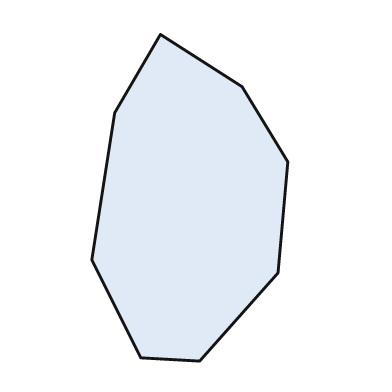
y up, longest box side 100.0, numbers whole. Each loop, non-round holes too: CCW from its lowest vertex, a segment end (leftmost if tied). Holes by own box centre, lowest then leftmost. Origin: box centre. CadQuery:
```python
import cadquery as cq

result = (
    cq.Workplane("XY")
    .moveTo(3.0, -50.0)
    .lineTo(27.0, -23.0)
    .lineTo(30.0, 11.0)
    .lineTo(16.0, 34.0)
    .lineTo(-9.0, 50.0)
    .lineTo(-23.0, 26.0)
    .lineTo(-30.0, -19.0)
    .lineTo(-15.0, -49.0)
    .close()
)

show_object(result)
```